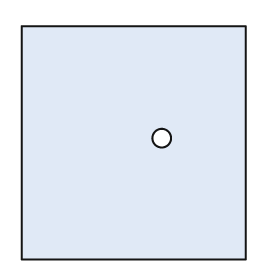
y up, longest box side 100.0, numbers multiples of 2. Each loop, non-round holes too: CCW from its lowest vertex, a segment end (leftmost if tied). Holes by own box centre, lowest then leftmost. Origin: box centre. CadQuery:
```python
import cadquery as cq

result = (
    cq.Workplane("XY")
    .moveTo(-48.0, -50.0)
    .lineTo(48.0, -50.0)
    .lineTo(48.0, 50.0)
    .lineTo(-48.0, 50.0)
    .close()
    .moveTo(12.0, 2.0)
    .circle(4.0)
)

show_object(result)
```